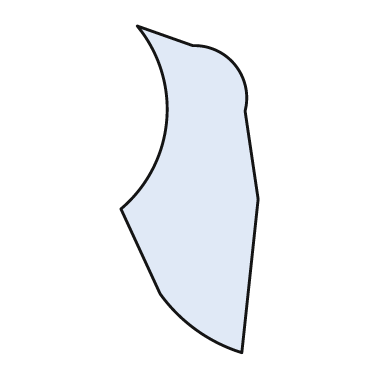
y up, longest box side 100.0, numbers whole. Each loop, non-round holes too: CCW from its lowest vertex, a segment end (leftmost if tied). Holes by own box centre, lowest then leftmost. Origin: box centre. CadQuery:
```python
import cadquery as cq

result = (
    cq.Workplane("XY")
    .moveTo(16.0, -50.0)
    .lineTo(21.0, -3.0)
    .lineTo(17.0, 24.0)
    .threePointArc((14.0, 38.0), (1.0, 44.0))
    .lineTo(-16.0, 50.0)
    .threePointArc((-7.0, 21.0), (-21.0, -6.0))
    .lineTo(-9.0, -32.0)
    .threePointArc((2.0, -43.0), (16.0, -50.0))
    .close()
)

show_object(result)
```